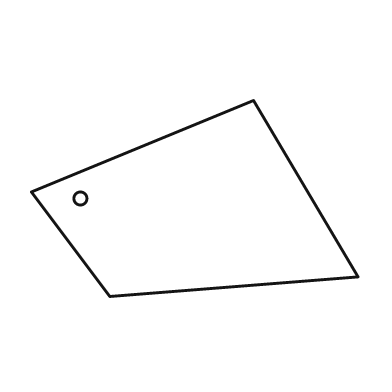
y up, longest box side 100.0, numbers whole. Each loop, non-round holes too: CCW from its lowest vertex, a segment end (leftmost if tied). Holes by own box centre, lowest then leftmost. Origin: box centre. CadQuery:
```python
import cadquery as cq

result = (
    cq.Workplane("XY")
    .moveTo(-26.0, -30.0)
    .lineTo(50.0, -24.0)
    .lineTo(18.0, 30.0)
    .lineTo(-50.0, 2.0)
    .close()
    .moveTo(-35.0, 0.0)
    .circle(2.0)
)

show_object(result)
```